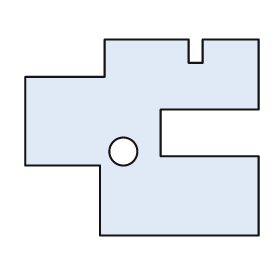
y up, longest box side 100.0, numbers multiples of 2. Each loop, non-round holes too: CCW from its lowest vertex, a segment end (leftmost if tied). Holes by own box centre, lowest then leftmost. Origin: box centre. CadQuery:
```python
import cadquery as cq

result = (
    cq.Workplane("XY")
    .moveTo(-18.0, -42.0)
    .lineTo(50.0, -42.0)
    .lineTo(50.0, -8.0)
    .lineTo(8.0, -8.0)
    .lineTo(8.0, 12.0)
    .lineTo(50.0, 12.0)
    .lineTo(50.0, 42.0)
    .lineTo(26.0, 42.0)
    .lineTo(26.0, 32.0)
    .lineTo(20.0, 32.0)
    .lineTo(20.0, 42.0)
    .lineTo(-16.0, 42.0)
    .lineTo(-16.0, 26.0)
    .lineTo(-50.0, 26.0)
    .lineTo(-50.0, -12.0)
    .lineTo(-18.0, -12.0)
    .close()
    .moveTo(-8.0, -6.0)
    .circle(6.0)
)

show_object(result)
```